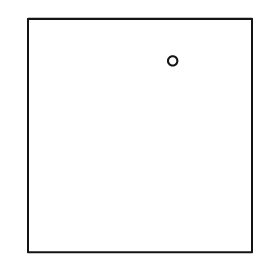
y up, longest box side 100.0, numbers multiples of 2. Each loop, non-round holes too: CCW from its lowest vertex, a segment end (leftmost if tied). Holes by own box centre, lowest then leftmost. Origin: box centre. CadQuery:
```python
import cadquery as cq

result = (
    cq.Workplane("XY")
    .moveTo(-48.0, -50.0)
    .lineTo(48.0, -50.0)
    .lineTo(48.0, 50.0)
    .lineTo(-48.0, 50.0)
    .close()
    .moveTo(14.0, 32.0)
    .circle(2.0)
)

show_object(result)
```